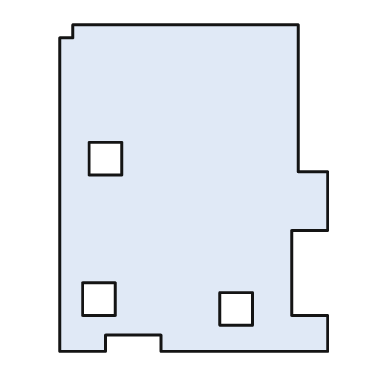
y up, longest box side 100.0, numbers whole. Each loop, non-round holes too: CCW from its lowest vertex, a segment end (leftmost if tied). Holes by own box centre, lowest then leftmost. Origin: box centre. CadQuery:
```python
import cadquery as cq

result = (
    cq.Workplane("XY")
    .moveTo(-41.0, -50.0)
    .lineTo(-27.0, -50.0)
    .lineTo(-27.0, -45.0)
    .lineTo(-10.0, -45.0)
    .lineTo(-10.0, -50.0)
    .lineTo(41.0, -50.0)
    .lineTo(41.0, -39.0)
    .lineTo(30.0, -39.0)
    .lineTo(30.0, -13.0)
    .lineTo(41.0, -13.0)
    .lineTo(41.0, 5.0)
    .lineTo(32.0, 5.0)
    .lineTo(32.0, 50.0)
    .lineTo(-37.0, 50.0)
    .lineTo(-37.0, 46.0)
    .lineTo(-41.0, 46.0)
    .close()
    .moveTo(8.0, -42.0)
    .lineTo(18.0, -42.0)
    .lineTo(18.0, -32.0)
    .lineTo(8.0, -32.0)
    .close()
    .moveTo(-34.0, -39.0)
    .lineTo(-24.0, -39.0)
    .lineTo(-24.0, -29.0)
    .lineTo(-34.0, -29.0)
    .close()
    .moveTo(-32.0, 4.0)
    .lineTo(-22.0, 4.0)
    .lineTo(-22.0, 14.0)
    .lineTo(-32.0, 14.0)
    .close()
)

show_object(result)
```